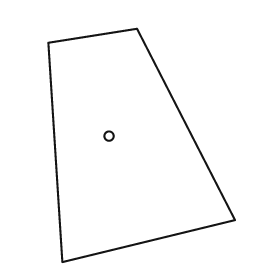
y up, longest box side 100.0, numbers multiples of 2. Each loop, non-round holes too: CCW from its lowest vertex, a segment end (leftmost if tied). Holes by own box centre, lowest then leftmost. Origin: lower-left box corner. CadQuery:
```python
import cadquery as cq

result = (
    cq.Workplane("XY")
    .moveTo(6.0, 0.0)
    .lineTo(80.0, 18.0)
    .lineTo(38.0, 100.0)
    .lineTo(0.0, 94.0)
    .close()
    .moveTo(26.0, 54.0)
    .circle(2.0)
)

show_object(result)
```